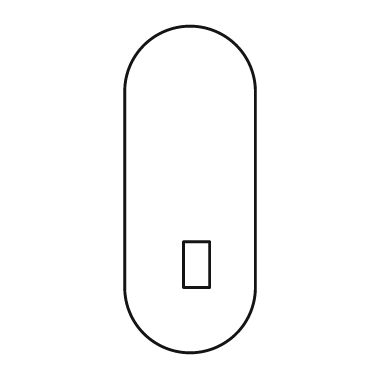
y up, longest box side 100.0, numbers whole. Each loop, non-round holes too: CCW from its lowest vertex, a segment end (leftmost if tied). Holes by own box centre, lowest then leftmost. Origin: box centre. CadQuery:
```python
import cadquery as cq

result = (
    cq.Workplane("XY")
    .moveTo(-20.0, -30.0)
    .threePointArc((0.0, -50.0), (20.0, -30.0))
    .lineTo(20.0, 30.0)
    .threePointArc((0.0, 50.0), (-20.0, 30.0))
    .close()
    .moveTo(-2.0, -30.0)
    .lineTo(6.0, -30.0)
    .lineTo(6.0, -16.0)
    .lineTo(-2.0, -16.0)
    .close()
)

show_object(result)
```